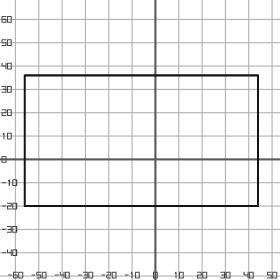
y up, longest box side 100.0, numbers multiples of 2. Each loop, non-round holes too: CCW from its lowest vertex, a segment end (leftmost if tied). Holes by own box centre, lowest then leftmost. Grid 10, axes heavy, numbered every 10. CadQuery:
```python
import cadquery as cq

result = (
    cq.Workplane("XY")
    .moveTo(-56.0, -20.0)
    .lineTo(44.0, -20.0)
    .lineTo(44.0, 36.0)
    .lineTo(-56.0, 36.0)
    .close()
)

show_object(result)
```